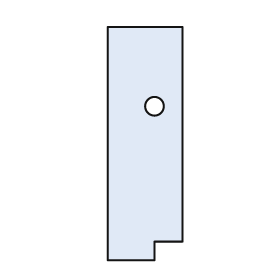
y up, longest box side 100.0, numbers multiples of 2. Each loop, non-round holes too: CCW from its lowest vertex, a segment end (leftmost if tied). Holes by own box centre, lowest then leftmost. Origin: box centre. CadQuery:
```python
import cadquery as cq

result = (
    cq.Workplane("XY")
    .moveTo(-16.0, -50.0)
    .lineTo(4.0, -50.0)
    .lineTo(4.0, -42.0)
    .lineTo(16.0, -42.0)
    .lineTo(16.0, 50.0)
    .lineTo(-16.0, 50.0)
    .close()
    .moveTo(4.0, 16.0)
    .circle(4.0)
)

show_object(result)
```